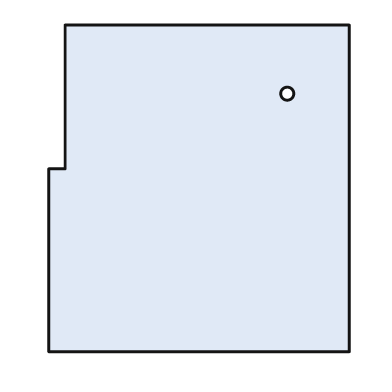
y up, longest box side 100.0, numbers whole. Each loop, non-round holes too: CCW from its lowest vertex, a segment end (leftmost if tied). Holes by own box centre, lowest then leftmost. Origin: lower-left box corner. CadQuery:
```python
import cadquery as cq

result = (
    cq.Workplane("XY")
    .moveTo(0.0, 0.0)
    .lineTo(92.0, 0.0)
    .lineTo(92.0, 100.0)
    .lineTo(5.0, 100.0)
    .lineTo(5.0, 56.0)
    .lineTo(0.0, 56.0)
    .close()
    .moveTo(73.0, 79.0)
    .circle(2.0)
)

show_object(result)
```